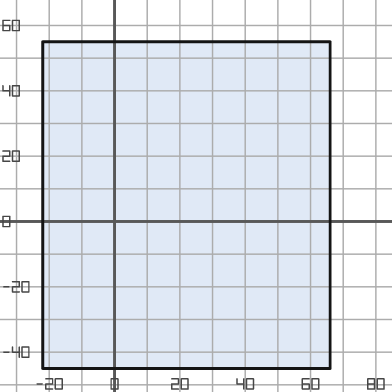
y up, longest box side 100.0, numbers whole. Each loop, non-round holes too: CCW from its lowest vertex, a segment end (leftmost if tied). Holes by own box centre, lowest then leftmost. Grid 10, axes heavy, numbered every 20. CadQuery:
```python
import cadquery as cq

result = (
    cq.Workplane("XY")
    .moveTo(-22.0, -45.0)
    .lineTo(66.0, -45.0)
    .lineTo(66.0, 55.0)
    .lineTo(-22.0, 55.0)
    .close()
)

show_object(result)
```